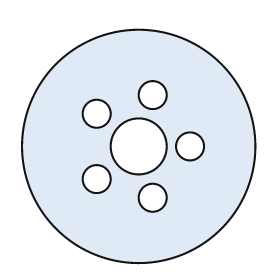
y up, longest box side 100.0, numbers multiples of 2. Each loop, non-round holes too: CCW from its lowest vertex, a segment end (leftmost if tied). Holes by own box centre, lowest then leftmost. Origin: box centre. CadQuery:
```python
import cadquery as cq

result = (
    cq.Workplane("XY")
    .moveTo(0.0, 0.0)
    .circle(50.0)
    .moveTo(6.0, -22.0)
    .circle(6.0)
    .moveTo(-18.0, -14.0)
    .circle(6.0)
    .moveTo(0.0, 0.0)
    .circle(12.0)
    .moveTo(22.0, 0.0)
    .circle(6.0)
    .moveTo(-18.0, 14.0)
    .circle(6.0)
    .moveTo(6.0, 22.0)
    .circle(6.0)
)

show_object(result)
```